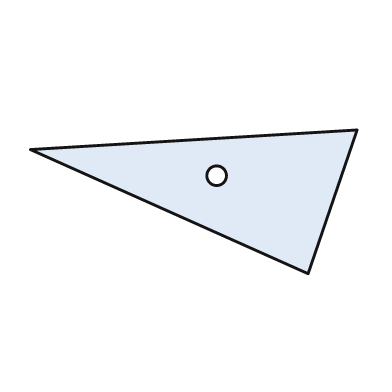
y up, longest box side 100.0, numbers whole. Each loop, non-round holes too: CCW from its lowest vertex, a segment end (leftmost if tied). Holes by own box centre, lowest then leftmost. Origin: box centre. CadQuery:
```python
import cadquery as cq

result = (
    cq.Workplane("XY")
    .moveTo(35.0, -22.0)
    .lineTo(50.0, 22.0)
    .lineTo(-50.0, 16.0)
    .close()
    .moveTo(7.0, 8.0)
    .circle(3.0)
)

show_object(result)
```